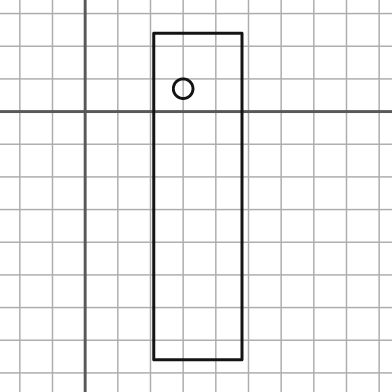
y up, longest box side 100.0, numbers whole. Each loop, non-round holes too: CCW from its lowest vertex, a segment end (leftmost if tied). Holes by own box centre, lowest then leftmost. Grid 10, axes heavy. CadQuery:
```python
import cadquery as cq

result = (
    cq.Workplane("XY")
    .moveTo(21.0, -76.0)
    .lineTo(48.0, -76.0)
    .lineTo(48.0, 24.0)
    .lineTo(21.0, 24.0)
    .close()
    .moveTo(30.0, 7.0)
    .circle(3.0)
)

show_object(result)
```